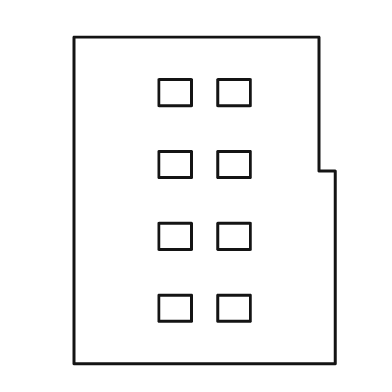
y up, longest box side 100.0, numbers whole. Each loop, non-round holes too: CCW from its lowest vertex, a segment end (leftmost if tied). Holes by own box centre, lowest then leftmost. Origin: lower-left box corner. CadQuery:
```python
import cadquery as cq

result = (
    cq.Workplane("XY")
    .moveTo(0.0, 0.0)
    .lineTo(80.0, 0.0)
    .lineTo(80.0, 59.0)
    .lineTo(75.0, 59.0)
    .lineTo(75.0, 100.0)
    .lineTo(0.0, 100.0)
    .close()
    .moveTo(26.0, 13.0)
    .lineTo(36.0, 13.0)
    .lineTo(36.0, 21.0)
    .lineTo(26.0, 21.0)
    .close()
    .moveTo(44.0, 13.0)
    .lineTo(54.0, 13.0)
    .lineTo(54.0, 21.0)
    .lineTo(44.0, 21.0)
    .close()
    .moveTo(26.0, 35.0)
    .lineTo(36.0, 35.0)
    .lineTo(36.0, 43.0)
    .lineTo(26.0, 43.0)
    .close()
    .moveTo(44.0, 35.0)
    .lineTo(54.0, 35.0)
    .lineTo(54.0, 43.0)
    .lineTo(44.0, 43.0)
    .close()
    .moveTo(26.0, 57.0)
    .lineTo(36.0, 57.0)
    .lineTo(36.0, 65.0)
    .lineTo(26.0, 65.0)
    .close()
    .moveTo(44.0, 57.0)
    .lineTo(54.0, 57.0)
    .lineTo(54.0, 65.0)
    .lineTo(44.0, 65.0)
    .close()
    .moveTo(26.0, 79.0)
    .lineTo(36.0, 79.0)
    .lineTo(36.0, 87.0)
    .lineTo(26.0, 87.0)
    .close()
    .moveTo(44.0, 79.0)
    .lineTo(54.0, 79.0)
    .lineTo(54.0, 87.0)
    .lineTo(44.0, 87.0)
    .close()
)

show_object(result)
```